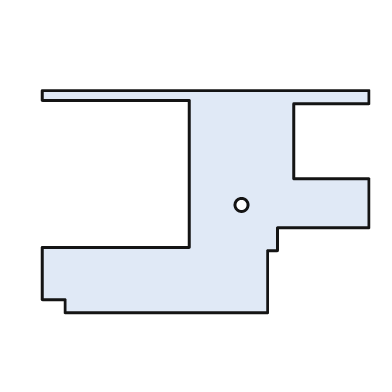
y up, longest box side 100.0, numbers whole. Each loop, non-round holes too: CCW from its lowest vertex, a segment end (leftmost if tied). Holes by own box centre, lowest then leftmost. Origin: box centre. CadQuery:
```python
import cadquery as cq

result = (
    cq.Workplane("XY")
    .moveTo(-43.0, -34.0)
    .lineTo(19.0, -34.0)
    .lineTo(19.0, -15.0)
    .lineTo(22.0, -15.0)
    .lineTo(22.0, -8.0)
    .lineTo(50.0, -8.0)
    .lineTo(50.0, 7.0)
    .lineTo(27.0, 7.0)
    .lineTo(27.0, 30.0)
    .lineTo(50.0, 30.0)
    .lineTo(50.0, 34.0)
    .lineTo(-50.0, 34.0)
    .lineTo(-50.0, 31.0)
    .lineTo(-5.0, 31.0)
    .lineTo(-5.0, -14.0)
    .lineTo(-50.0, -14.0)
    .lineTo(-50.0, -30.0)
    .lineTo(-43.0, -30.0)
    .close()
    .moveTo(11.0, -1.0)
    .circle(2.0)
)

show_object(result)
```